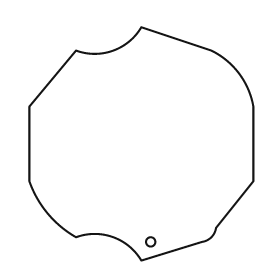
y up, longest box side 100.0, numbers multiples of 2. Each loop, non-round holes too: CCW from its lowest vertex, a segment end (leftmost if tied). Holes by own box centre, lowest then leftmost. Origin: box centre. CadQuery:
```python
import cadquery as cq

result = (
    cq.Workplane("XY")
    .moveTo(0.0, -50.0)
    .lineTo(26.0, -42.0)
    .threePointArc((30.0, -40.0), (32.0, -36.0))
    .lineTo(48.0, -16.0)
    .lineTo(48.0, 16.0)
    .threePointArc((42.0, 30.0), (30.0, 40.0))
    .lineTo(0.0, 50.0)
    .threePointArc((-12.0, 40.0), (-28.0, 40.0))
    .lineTo(-48.0, 16.0)
    .lineTo(-48.0, -16.0)
    .threePointArc((-40.0, -30.0), (-28.0, -40.0))
    .threePointArc((-12.0, -40.0), (0.0, -50.0))
    .close()
    .moveTo(4.0, -42.0)
    .circle(2.0)
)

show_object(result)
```